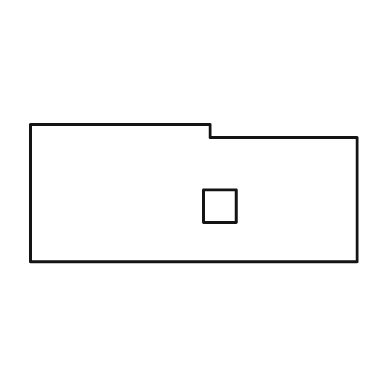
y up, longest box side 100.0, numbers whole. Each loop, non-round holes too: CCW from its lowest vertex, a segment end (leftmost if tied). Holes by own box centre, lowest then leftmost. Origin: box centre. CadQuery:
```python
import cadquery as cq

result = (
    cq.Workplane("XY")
    .moveTo(-50.0, -21.0)
    .lineTo(50.0, -21.0)
    .lineTo(50.0, 17.0)
    .lineTo(5.0, 17.0)
    .lineTo(5.0, 21.0)
    .lineTo(-50.0, 21.0)
    .close()
    .moveTo(3.0, -9.0)
    .lineTo(13.0, -9.0)
    .lineTo(13.0, 1.0)
    .lineTo(3.0, 1.0)
    .close()
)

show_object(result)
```